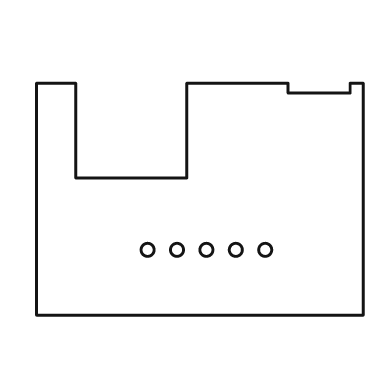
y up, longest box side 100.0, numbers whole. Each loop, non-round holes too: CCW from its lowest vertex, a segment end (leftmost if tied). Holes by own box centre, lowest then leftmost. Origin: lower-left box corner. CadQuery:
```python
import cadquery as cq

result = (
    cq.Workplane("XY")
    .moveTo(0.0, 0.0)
    .lineTo(100.0, 0.0)
    .lineTo(100.0, 71.0)
    .lineTo(96.0, 71.0)
    .lineTo(96.0, 68.0)
    .lineTo(77.0, 68.0)
    .lineTo(77.0, 71.0)
    .lineTo(46.0, 71.0)
    .lineTo(46.0, 42.0)
    .lineTo(12.0, 42.0)
    .lineTo(12.0, 71.0)
    .lineTo(0.0, 71.0)
    .close()
    .moveTo(34.0, 20.0)
    .circle(2.0)
    .moveTo(43.0, 20.0)
    .circle(2.0)
    .moveTo(52.0, 20.0)
    .circle(2.0)
    .moveTo(61.0, 20.0)
    .circle(2.0)
    .moveTo(70.0, 20.0)
    .circle(2.0)
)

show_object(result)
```